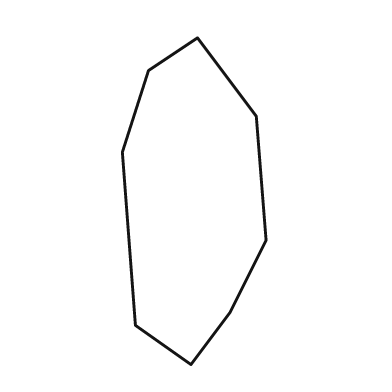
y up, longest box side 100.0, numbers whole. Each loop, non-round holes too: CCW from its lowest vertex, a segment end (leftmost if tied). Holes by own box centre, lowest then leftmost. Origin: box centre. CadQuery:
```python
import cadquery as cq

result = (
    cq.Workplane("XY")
    .moveTo(-1.0, -50.0)
    .lineTo(11.0, -34.0)
    .lineTo(22.0, -12.0)
    .lineTo(19.0, 26.0)
    .lineTo(1.0, 50.0)
    .lineTo(-14.0, 40.0)
    .lineTo(-22.0, 15.0)
    .lineTo(-18.0, -38.0)
    .close()
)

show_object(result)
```